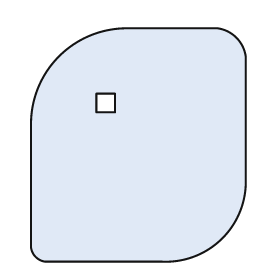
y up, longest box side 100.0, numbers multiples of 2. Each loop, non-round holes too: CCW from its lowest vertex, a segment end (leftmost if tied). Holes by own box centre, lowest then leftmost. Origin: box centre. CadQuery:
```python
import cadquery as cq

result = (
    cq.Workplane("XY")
    .moveTo(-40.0, -50.0)
    .lineTo(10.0, -50.0)
    .threePointArc((36.0, -40.0), (46.0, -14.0))
    .lineTo(46.0, 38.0)
    .threePointArc((42.0, 46.0), (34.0, 50.0))
    .lineTo(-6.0, 50.0)
    .threePointArc((-34.0, 38.0), (-46.0, 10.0))
    .lineTo(-46.0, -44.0)
    .threePointArc((-44.0, -48.0), (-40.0, -50.0))
    .close()
    .moveTo(-18.0, 14.0)
    .lineTo(-10.0, 14.0)
    .lineTo(-10.0, 22.0)
    .lineTo(-18.0, 22.0)
    .close()
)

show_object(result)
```